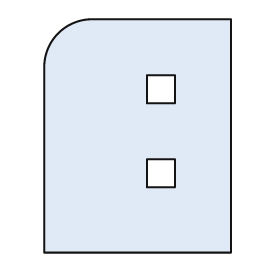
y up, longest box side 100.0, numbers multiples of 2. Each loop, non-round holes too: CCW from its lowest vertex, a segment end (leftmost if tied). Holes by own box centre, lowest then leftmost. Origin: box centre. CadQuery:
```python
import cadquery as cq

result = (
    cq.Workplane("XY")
    .moveTo(-40.0, -50.0)
    .lineTo(40.0, -50.0)
    .lineTo(40.0, 50.0)
    .lineTo(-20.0, 50.0)
    .threePointArc((-34.0, 44.0), (-40.0, 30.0))
    .close()
    .moveTo(4.0, -22.0)
    .lineTo(16.0, -22.0)
    .lineTo(16.0, -10.0)
    .lineTo(4.0, -10.0)
    .close()
    .moveTo(4.0, 14.0)
    .lineTo(16.0, 14.0)
    .lineTo(16.0, 26.0)
    .lineTo(4.0, 26.0)
    .close()
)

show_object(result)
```